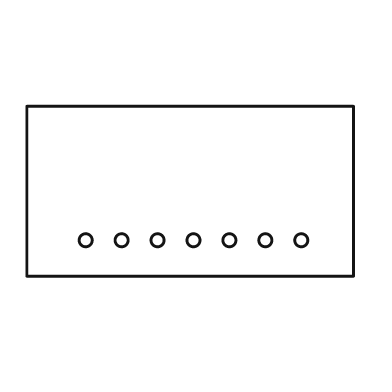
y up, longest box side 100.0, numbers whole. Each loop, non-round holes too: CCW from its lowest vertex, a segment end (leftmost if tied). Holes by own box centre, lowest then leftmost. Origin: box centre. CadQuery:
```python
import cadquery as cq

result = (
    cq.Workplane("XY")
    .moveTo(-50.0, -26.0)
    .lineTo(50.0, -26.0)
    .lineTo(50.0, 26.0)
    .lineTo(-50.0, 26.0)
    .close()
    .moveTo(-32.0, -15.0)
    .circle(2.0)
    .moveTo(-21.0, -15.0)
    .circle(2.0)
    .moveTo(-10.0, -15.0)
    .circle(2.0)
    .moveTo(1.0, -15.0)
    .circle(2.0)
    .moveTo(12.0, -15.0)
    .circle(2.0)
    .moveTo(23.0, -15.0)
    .circle(2.0)
    .moveTo(34.0, -15.0)
    .circle(2.0)
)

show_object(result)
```